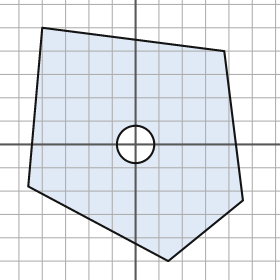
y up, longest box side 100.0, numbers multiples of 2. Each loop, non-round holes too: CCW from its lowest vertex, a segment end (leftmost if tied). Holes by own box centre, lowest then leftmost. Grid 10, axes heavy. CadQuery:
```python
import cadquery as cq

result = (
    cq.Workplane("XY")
    .moveTo(14.0, -50.0)
    .lineTo(46.0, -24.0)
    .lineTo(38.0, 40.0)
    .lineTo(-40.0, 50.0)
    .lineTo(-46.0, -18.0)
    .close()
    .moveTo(0.0, 0.0)
    .circle(8.0)
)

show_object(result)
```